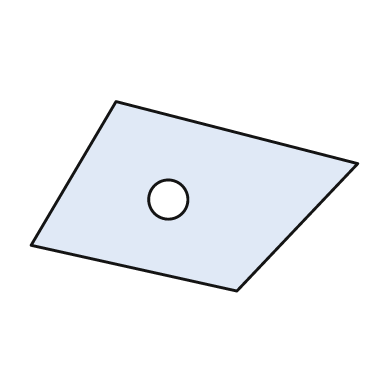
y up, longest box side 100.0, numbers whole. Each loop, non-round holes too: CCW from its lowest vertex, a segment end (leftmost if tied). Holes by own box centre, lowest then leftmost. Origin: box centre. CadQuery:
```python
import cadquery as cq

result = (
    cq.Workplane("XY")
    .moveTo(13.0, -29.0)
    .lineTo(50.0, 10.0)
    .lineTo(-24.0, 29.0)
    .lineTo(-50.0, -15.0)
    .close()
    .moveTo(-8.0, -1.0)
    .circle(6.0)
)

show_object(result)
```